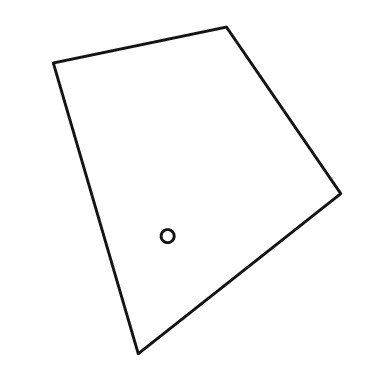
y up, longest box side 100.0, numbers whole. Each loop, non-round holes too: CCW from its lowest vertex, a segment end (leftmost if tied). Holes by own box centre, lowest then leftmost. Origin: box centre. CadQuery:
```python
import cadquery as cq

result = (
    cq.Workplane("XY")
    .moveTo(-18.0, -50.0)
    .lineTo(44.0, -1.0)
    .lineTo(9.0, 50.0)
    .lineTo(-44.0, 39.0)
    .close()
    .moveTo(-9.0, -14.0)
    .circle(2.0)
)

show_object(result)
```